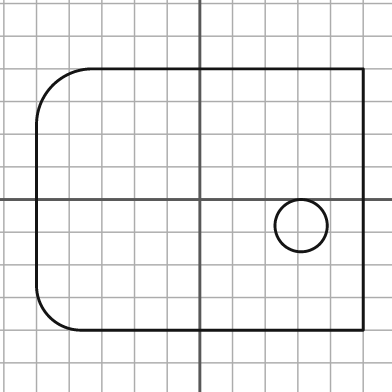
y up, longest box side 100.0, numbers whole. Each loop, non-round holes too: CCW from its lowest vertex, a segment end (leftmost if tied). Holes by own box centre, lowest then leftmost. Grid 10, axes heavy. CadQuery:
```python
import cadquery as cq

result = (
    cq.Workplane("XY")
    .moveTo(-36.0, -40.0)
    .lineTo(50.0, -40.0)
    .lineTo(50.0, 40.0)
    .lineTo(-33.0, 40.0)
    .threePointArc((-45.0, 35.0), (-50.0, 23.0))
    .lineTo(-50.0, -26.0)
    .threePointArc((-46.0, -36.0), (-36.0, -40.0))
    .close()
    .moveTo(31.0, -8.0)
    .circle(8.0)
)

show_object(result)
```